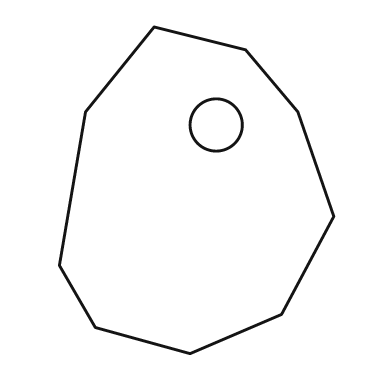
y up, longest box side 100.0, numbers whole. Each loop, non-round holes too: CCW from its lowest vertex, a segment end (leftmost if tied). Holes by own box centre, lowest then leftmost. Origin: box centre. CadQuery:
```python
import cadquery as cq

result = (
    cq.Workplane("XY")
    .moveTo(-2.0, -50.0)
    .lineTo(26.0, -38.0)
    .lineTo(42.0, -8.0)
    .lineTo(31.0, 24.0)
    .lineTo(15.0, 43.0)
    .lineTo(-13.0, 50.0)
    .lineTo(-34.0, 24.0)
    .lineTo(-42.0, -23.0)
    .lineTo(-31.0, -42.0)
    .close()
    .moveTo(6.0, 20.0)
    .circle(8.0)
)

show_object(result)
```